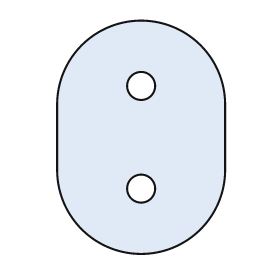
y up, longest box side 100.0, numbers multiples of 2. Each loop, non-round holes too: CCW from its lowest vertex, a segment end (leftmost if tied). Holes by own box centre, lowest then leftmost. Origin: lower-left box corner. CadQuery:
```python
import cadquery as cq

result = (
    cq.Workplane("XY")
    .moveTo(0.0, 36.0)
    .threePointArc((36.0, 0.0), (72.0, 36.0))
    .lineTo(72.0, 64.0)
    .threePointArc((36.0, 100.0), (0.0, 64.0))
    .close()
    .moveTo(36.0, 28.0)
    .circle(6.0)
    .moveTo(36.0, 72.0)
    .circle(6.0)
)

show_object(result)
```